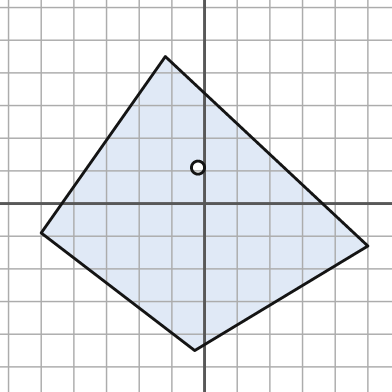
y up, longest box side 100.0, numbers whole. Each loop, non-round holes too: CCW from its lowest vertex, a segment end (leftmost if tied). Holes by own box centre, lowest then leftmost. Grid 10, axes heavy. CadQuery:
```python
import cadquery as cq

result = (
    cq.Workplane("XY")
    .moveTo(-3.0, -45.0)
    .lineTo(50.0, -13.0)
    .lineTo(-12.0, 45.0)
    .lineTo(-50.0, -9.0)
    .close()
    .moveTo(-2.0, 11.0)
    .circle(2.0)
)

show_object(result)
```